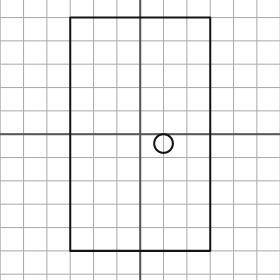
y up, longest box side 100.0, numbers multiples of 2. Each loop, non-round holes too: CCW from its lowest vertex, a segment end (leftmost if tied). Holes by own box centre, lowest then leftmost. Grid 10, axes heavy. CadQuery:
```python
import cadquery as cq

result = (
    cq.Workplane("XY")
    .moveTo(-30.0, -50.0)
    .lineTo(30.0, -50.0)
    .lineTo(30.0, 50.0)
    .lineTo(-30.0, 50.0)
    .close()
    .moveTo(10.0, -4.0)
    .circle(4.0)
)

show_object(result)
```